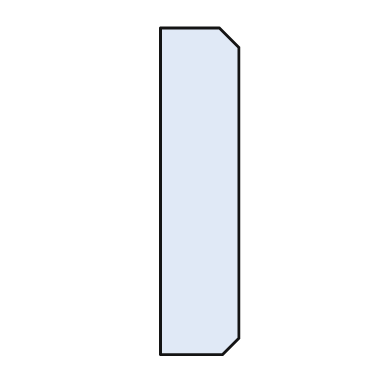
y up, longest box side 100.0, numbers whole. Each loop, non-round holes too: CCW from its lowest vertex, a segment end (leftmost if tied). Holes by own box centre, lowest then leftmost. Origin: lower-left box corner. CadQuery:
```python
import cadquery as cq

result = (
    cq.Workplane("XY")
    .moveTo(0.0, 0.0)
    .lineTo(19.0, 0.0)
    .lineTo(24.0, 5.0)
    .lineTo(24.0, 94.0)
    .lineTo(18.0, 100.0)
    .lineTo(0.0, 100.0)
    .close()
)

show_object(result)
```